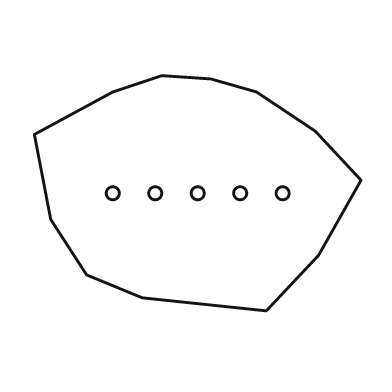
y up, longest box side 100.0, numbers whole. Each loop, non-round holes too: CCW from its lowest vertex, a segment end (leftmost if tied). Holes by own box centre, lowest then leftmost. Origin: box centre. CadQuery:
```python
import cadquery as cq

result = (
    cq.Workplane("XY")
    .moveTo(21.0, -36.0)
    .lineTo(37.0, -19.0)
    .lineTo(50.0, 4.0)
    .lineTo(36.0, 19.0)
    .lineTo(18.0, 31.0)
    .lineTo(4.0, 35.0)
    .lineTo(-11.0, 36.0)
    .lineTo(-26.0, 31.0)
    .lineTo(-50.0, 18.0)
    .lineTo(-45.0, -8.0)
    .lineTo(-34.0, -25.0)
    .lineTo(-17.0, -32.0)
    .close()
    .moveTo(-26.0, 0.0)
    .circle(2.0)
    .moveTo(-13.0, 0.0)
    .circle(2.0)
    .moveTo(0.0, 0.0)
    .circle(2.0)
    .moveTo(13.0, 0.0)
    .circle(2.0)
    .moveTo(26.0, 0.0)
    .circle(2.0)
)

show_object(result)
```